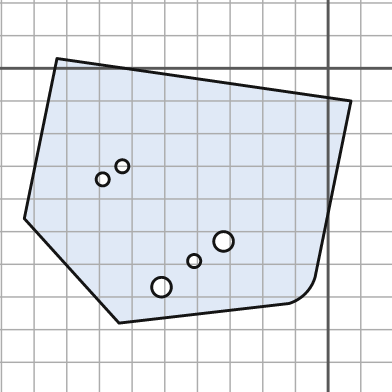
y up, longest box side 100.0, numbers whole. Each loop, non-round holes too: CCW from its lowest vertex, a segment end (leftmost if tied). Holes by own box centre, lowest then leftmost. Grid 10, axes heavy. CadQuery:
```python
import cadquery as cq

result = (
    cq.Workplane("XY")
    .moveTo(-64.0, -78.0)
    .lineTo(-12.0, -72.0)
    .threePointArc((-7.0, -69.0), (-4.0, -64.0))
    .lineTo(7.0, -10.0)
    .lineTo(-83.0, 3.0)
    .lineTo(-93.0, -46.0)
    .close()
    .moveTo(-51.0, -67.0)
    .circle(3.0)
    .moveTo(-41.0, -59.0)
    .circle(2.0)
    .moveTo(-32.0, -53.0)
    .circle(3.0)
    .moveTo(-69.0, -34.0)
    .circle(2.0)
    .moveTo(-63.0, -30.0)
    .circle(2.0)
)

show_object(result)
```